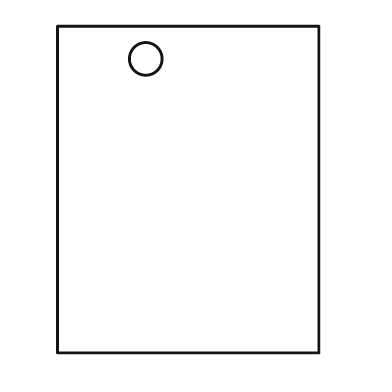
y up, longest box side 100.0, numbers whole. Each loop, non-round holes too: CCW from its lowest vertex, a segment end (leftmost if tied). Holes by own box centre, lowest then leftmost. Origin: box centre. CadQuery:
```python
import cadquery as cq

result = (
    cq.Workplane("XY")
    .moveTo(-40.0, -50.0)
    .lineTo(40.0, -50.0)
    .lineTo(40.0, 50.0)
    .lineTo(-40.0, 50.0)
    .close()
    .moveTo(-13.0, 40.0)
    .circle(5.0)
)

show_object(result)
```